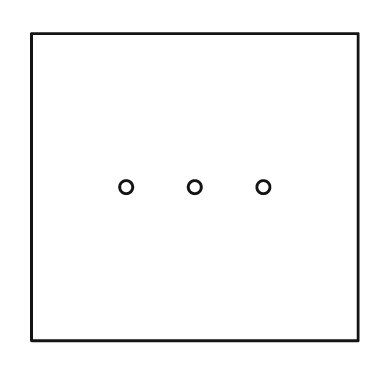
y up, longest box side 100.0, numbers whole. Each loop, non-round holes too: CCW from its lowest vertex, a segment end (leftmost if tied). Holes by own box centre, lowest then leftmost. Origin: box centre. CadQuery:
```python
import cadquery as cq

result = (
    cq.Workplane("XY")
    .moveTo(-50.0, -47.0)
    .lineTo(50.0, -47.0)
    .lineTo(50.0, 47.0)
    .lineTo(-50.0, 47.0)
    .close()
    .moveTo(-21.0, 0.0)
    .circle(2.0)
    .moveTo(0.0, 0.0)
    .circle(2.0)
    .moveTo(21.0, 0.0)
    .circle(2.0)
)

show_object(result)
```